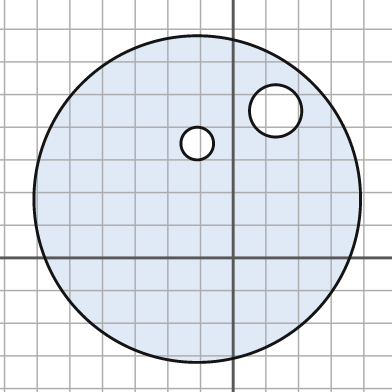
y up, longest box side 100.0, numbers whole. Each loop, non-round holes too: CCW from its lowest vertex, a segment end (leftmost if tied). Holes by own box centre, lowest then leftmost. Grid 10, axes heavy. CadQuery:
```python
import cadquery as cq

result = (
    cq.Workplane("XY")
    .moveTo(-11.0, 18.0)
    .circle(50.0)
    .moveTo(-11.0, 35.0)
    .circle(5.0)
    .moveTo(13.0, 45.0)
    .circle(8.0)
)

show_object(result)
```